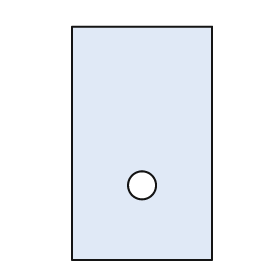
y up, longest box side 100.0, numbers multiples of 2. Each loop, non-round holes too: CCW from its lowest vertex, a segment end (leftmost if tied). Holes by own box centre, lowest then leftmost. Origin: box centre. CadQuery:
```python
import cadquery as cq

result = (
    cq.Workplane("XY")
    .moveTo(-30.0, -50.0)
    .lineTo(30.0, -50.0)
    .lineTo(30.0, 50.0)
    .lineTo(-30.0, 50.0)
    .close()
    .moveTo(0.0, -18.0)
    .circle(6.0)
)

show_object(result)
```